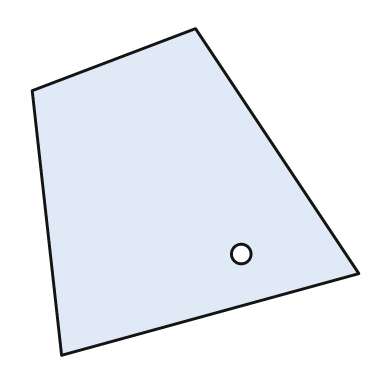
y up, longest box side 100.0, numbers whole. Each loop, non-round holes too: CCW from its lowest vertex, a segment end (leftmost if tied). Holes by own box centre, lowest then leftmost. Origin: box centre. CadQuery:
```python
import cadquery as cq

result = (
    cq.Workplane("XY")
    .moveTo(-41.0, -50.0)
    .lineTo(50.0, -25.0)
    .lineTo(0.0, 50.0)
    .lineTo(-50.0, 31.0)
    .close()
    .moveTo(14.0, -19.0)
    .circle(3.0)
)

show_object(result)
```